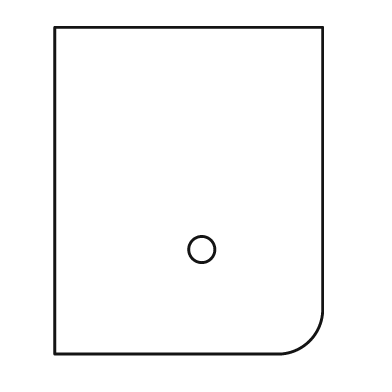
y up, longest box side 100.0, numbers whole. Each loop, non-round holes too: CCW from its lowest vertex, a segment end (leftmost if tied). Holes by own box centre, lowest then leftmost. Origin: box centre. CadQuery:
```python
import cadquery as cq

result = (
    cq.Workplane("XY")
    .moveTo(-41.0, -50.0)
    .lineTo(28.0, -50.0)
    .threePointArc((37.0, -46.0), (41.0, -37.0))
    .lineTo(41.0, 50.0)
    .lineTo(-41.0, 50.0)
    .close()
    .moveTo(4.0, -18.0)
    .circle(4.0)
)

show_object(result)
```